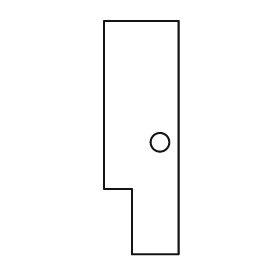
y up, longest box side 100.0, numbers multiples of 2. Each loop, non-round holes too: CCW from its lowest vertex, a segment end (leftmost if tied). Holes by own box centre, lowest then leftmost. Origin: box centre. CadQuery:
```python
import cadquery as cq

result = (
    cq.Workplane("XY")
    .moveTo(-4.0, -50.0)
    .lineTo(16.0, -50.0)
    .lineTo(16.0, 50.0)
    .lineTo(-16.0, 50.0)
    .lineTo(-16.0, -22.0)
    .lineTo(-4.0, -22.0)
    .close()
    .moveTo(8.0, -2.0)
    .circle(4.0)
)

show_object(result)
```